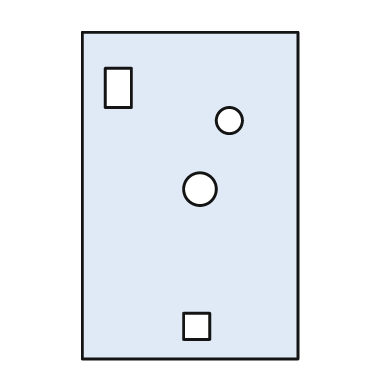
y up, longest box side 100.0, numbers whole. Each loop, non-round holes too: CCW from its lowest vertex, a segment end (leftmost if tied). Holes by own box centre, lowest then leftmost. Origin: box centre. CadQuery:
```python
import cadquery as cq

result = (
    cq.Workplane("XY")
    .moveTo(-33.0, -50.0)
    .lineTo(33.0, -50.0)
    .lineTo(33.0, 50.0)
    .lineTo(-33.0, 50.0)
    .close()
    .moveTo(-2.0, -44.0)
    .lineTo(6.0, -44.0)
    .lineTo(6.0, -36.0)
    .lineTo(-2.0, -36.0)
    .close()
    .moveTo(3.0, 2.0)
    .circle(5.0)
    .moveTo(12.0, 23.0)
    .circle(4.0)
    .moveTo(-26.0, 27.0)
    .lineTo(-18.0, 27.0)
    .lineTo(-18.0, 39.0)
    .lineTo(-26.0, 39.0)
    .close()
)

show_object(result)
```